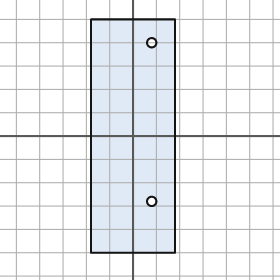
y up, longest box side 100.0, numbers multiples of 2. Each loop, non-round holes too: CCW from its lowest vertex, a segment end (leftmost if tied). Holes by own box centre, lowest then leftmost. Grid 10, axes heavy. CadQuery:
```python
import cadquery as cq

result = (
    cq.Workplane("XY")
    .moveTo(-18.0, -50.0)
    .lineTo(18.0, -50.0)
    .lineTo(18.0, 50.0)
    .lineTo(-18.0, 50.0)
    .close()
    .moveTo(8.0, -28.0)
    .circle(2.0)
    .moveTo(8.0, 40.0)
    .circle(2.0)
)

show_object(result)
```